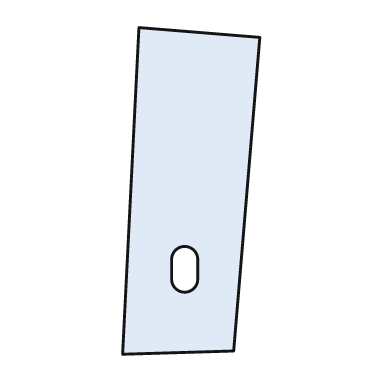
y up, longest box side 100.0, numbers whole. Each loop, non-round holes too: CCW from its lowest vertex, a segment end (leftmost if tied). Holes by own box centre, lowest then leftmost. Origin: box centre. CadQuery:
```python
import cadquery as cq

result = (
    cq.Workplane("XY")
    .moveTo(-21.0, -50.0)
    .lineTo(13.0, -49.0)
    .lineTo(21.0, 47.0)
    .lineTo(-16.0, 50.0)
    .close()
    .moveTo(-6.0, -27.0)
    .threePointArc((-2.0, -31.0), (2.0, -27.0))
    .lineTo(2.0, -21.0)
    .threePointArc((-2.0, -17.0), (-6.0, -21.0))
    .close()
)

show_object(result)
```